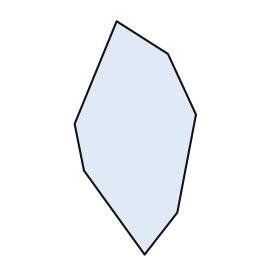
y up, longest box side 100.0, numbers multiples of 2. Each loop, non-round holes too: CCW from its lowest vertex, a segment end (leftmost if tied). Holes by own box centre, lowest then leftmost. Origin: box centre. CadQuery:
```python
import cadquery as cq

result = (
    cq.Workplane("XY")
    .moveTo(4.0, -50.0)
    .lineTo(18.0, -32.0)
    .lineTo(26.0, 10.0)
    .lineTo(14.0, 36.0)
    .lineTo(-8.0, 50.0)
    .lineTo(-26.0, 6.0)
    .lineTo(-22.0, -14.0)
    .close()
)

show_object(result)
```